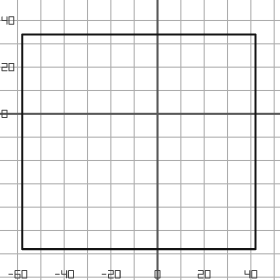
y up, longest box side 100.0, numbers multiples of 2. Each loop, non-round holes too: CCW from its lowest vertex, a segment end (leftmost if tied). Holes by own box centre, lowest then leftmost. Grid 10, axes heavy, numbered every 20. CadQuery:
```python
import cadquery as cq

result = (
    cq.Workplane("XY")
    .moveTo(-58.0, -58.0)
    .lineTo(42.0, -58.0)
    .lineTo(42.0, 34.0)
    .lineTo(-58.0, 34.0)
    .close()
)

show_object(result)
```